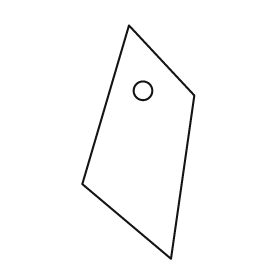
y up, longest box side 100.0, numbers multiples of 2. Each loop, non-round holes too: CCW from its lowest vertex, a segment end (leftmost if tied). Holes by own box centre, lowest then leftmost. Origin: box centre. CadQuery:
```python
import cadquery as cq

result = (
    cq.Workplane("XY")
    .moveTo(14.0, -50.0)
    .lineTo(24.0, 20.0)
    .lineTo(-4.0, 50.0)
    .lineTo(-24.0, -18.0)
    .close()
    .moveTo(2.0, 22.0)
    .circle(4.0)
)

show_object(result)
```